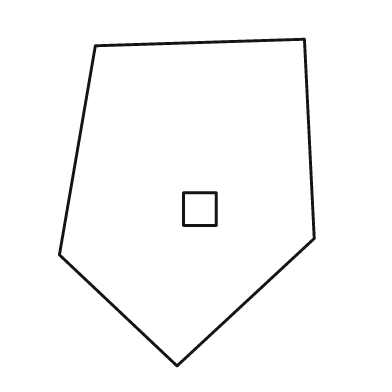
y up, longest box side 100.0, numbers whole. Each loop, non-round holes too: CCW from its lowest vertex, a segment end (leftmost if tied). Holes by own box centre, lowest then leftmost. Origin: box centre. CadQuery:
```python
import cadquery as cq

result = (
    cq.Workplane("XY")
    .moveTo(-3.0, -50.0)
    .lineTo(39.0, -11.0)
    .lineTo(36.0, 50.0)
    .lineTo(-28.0, 48.0)
    .lineTo(-39.0, -16.0)
    .close()
    .moveTo(-1.0, -7.0)
    .lineTo(9.0, -7.0)
    .lineTo(9.0, 3.0)
    .lineTo(-1.0, 3.0)
    .close()
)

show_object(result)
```